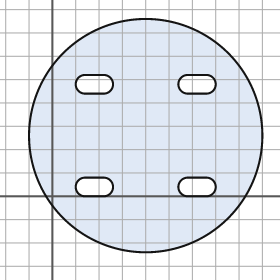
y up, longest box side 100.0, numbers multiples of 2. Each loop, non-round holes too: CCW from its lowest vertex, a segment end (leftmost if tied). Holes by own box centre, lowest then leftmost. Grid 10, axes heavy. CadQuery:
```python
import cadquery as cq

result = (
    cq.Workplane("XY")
    .moveTo(40.0, 26.0)
    .circle(50.0)
    .moveTo(14.0, 0.0)
    .lineTo(22.0, 0.0)
    .threePointArc((26.0, 4.0), (22.0, 8.0))
    .lineTo(14.0, 8.0)
    .threePointArc((10.0, 4.0), (14.0, 0.0))
    .close()
    .moveTo(58.0, 0.0)
    .lineTo(66.0, 0.0)
    .threePointArc((70.0, 4.0), (66.0, 8.0))
    .lineTo(58.0, 8.0)
    .threePointArc((54.0, 4.0), (58.0, 0.0))
    .close()
    .moveTo(14.0, 44.0)
    .lineTo(22.0, 44.0)
    .threePointArc((26.0, 48.0), (22.0, 52.0))
    .lineTo(14.0, 52.0)
    .threePointArc((10.0, 48.0), (14.0, 44.0))
    .close()
    .moveTo(58.0, 44.0)
    .lineTo(66.0, 44.0)
    .threePointArc((70.0, 48.0), (66.0, 52.0))
    .lineTo(58.0, 52.0)
    .threePointArc((54.0, 48.0), (58.0, 44.0))
    .close()
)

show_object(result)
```